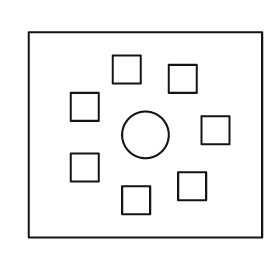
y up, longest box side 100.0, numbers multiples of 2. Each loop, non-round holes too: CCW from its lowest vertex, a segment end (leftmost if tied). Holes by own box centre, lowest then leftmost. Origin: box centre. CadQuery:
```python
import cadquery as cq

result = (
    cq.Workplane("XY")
    .moveTo(-50.0, -44.0)
    .lineTo(50.0, -44.0)
    .lineTo(50.0, 44.0)
    .lineTo(-50.0, 44.0)
    .close()
    .moveTo(-10.0, -34.0)
    .lineTo(2.0, -34.0)
    .lineTo(2.0, -22.0)
    .lineTo(-10.0, -22.0)
    .close()
    .moveTo(14.0, -28.0)
    .lineTo(26.0, -28.0)
    .lineTo(26.0, -16.0)
    .lineTo(14.0, -16.0)
    .close()
    .moveTo(-32.0, -20.0)
    .lineTo(-20.0, -20.0)
    .lineTo(-20.0, -8.0)
    .lineTo(-32.0, -8.0)
    .close()
    .moveTo(0.0, 0.0)
    .circle(10.0)
    .moveTo(24.0, -4.0)
    .lineTo(36.0, -4.0)
    .lineTo(36.0, 8.0)
    .lineTo(24.0, 8.0)
    .close()
    .moveTo(-32.0, 6.0)
    .lineTo(-20.0, 6.0)
    .lineTo(-20.0, 18.0)
    .lineTo(-32.0, 18.0)
    .close()
    .moveTo(10.0, 18.0)
    .lineTo(22.0, 18.0)
    .lineTo(22.0, 30.0)
    .lineTo(10.0, 30.0)
    .close()
    .moveTo(-14.0, 22.0)
    .lineTo(-2.0, 22.0)
    .lineTo(-2.0, 34.0)
    .lineTo(-14.0, 34.0)
    .close()
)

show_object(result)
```